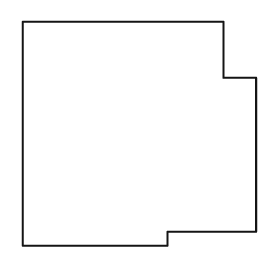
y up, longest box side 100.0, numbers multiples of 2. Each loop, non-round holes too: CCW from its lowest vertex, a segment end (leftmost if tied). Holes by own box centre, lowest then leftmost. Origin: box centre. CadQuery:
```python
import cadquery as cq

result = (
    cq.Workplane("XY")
    .moveTo(-50.0, -48.0)
    .lineTo(12.0, -48.0)
    .lineTo(12.0, -42.0)
    .lineTo(50.0, -42.0)
    .lineTo(50.0, 24.0)
    .lineTo(36.0, 24.0)
    .lineTo(36.0, 48.0)
    .lineTo(-50.0, 48.0)
    .close()
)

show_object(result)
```